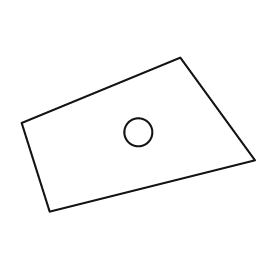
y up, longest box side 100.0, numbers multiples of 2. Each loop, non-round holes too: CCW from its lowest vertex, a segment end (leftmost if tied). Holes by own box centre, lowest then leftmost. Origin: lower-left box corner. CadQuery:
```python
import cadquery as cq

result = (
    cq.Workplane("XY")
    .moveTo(12.0, 0.0)
    .lineTo(100.0, 22.0)
    .lineTo(68.0, 66.0)
    .lineTo(0.0, 38.0)
    .close()
    .moveTo(50.0, 34.0)
    .circle(6.0)
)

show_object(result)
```